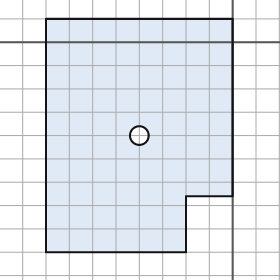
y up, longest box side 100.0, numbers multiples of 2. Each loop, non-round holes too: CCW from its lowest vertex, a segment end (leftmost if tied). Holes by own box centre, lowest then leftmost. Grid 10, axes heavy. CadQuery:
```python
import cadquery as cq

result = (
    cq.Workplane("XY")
    .moveTo(-80.0, -90.0)
    .lineTo(-20.0, -90.0)
    .lineTo(-20.0, -66.0)
    .lineTo(0.0, -66.0)
    .lineTo(0.0, 10.0)
    .lineTo(-80.0, 10.0)
    .close()
    .moveTo(-40.0, -40.0)
    .circle(4.0)
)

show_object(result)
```